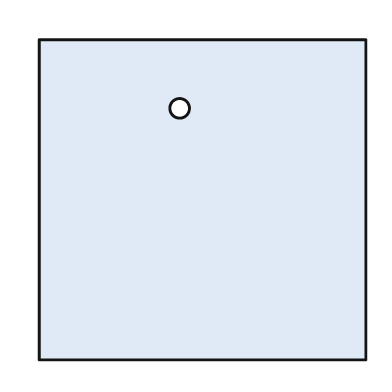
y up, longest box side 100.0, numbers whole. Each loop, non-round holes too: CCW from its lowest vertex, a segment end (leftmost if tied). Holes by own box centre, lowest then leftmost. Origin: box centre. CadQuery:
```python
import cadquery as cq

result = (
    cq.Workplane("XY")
    .moveTo(-50.0, -49.0)
    .lineTo(50.0, -49.0)
    .lineTo(50.0, 49.0)
    .lineTo(-50.0, 49.0)
    .close()
    .moveTo(-7.0, 28.0)
    .circle(3.0)
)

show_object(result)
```